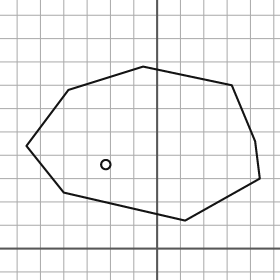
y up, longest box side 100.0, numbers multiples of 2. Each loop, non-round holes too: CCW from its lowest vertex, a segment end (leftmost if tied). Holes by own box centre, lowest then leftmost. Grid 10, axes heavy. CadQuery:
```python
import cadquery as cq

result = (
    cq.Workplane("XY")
    .moveTo(12.0, 12.0)
    .lineTo(44.0, 30.0)
    .lineTo(42.0, 46.0)
    .lineTo(32.0, 70.0)
    .lineTo(-6.0, 78.0)
    .lineTo(-38.0, 68.0)
    .lineTo(-56.0, 44.0)
    .lineTo(-40.0, 24.0)
    .close()
    .moveTo(-22.0, 36.0)
    .circle(2.0)
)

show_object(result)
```